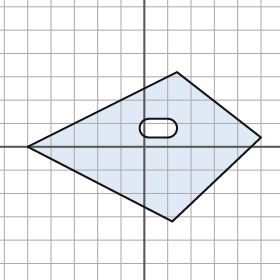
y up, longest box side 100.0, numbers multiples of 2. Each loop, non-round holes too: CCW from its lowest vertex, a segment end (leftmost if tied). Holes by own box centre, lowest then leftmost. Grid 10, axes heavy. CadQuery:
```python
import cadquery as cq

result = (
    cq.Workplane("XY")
    .moveTo(12.0, -32.0)
    .lineTo(50.0, 4.0)
    .lineTo(14.0, 32.0)
    .lineTo(-50.0, 0.0)
    .close()
    .moveTo(2.0, 4.0)
    .lineTo(10.0, 4.0)
    .threePointArc((14.0, 8.0), (10.0, 12.0))
    .lineTo(2.0, 12.0)
    .threePointArc((-2.0, 8.0), (2.0, 4.0))
    .close()
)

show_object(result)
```